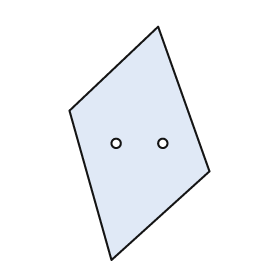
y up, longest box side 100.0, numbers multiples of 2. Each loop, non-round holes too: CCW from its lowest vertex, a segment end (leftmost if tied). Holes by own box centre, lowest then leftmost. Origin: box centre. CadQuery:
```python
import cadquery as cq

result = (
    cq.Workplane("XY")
    .moveTo(-12.0, -50.0)
    .lineTo(30.0, -12.0)
    .lineTo(8.0, 50.0)
    .lineTo(-30.0, 14.0)
    .close()
    .moveTo(-10.0, 0.0)
    .circle(2.0)
    .moveTo(10.0, 0.0)
    .circle(2.0)
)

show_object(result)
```